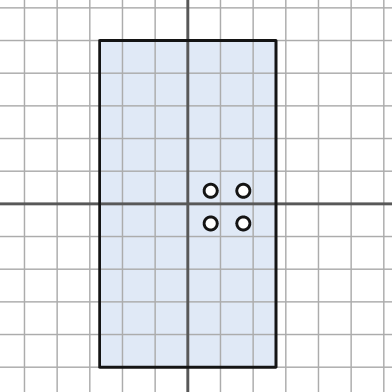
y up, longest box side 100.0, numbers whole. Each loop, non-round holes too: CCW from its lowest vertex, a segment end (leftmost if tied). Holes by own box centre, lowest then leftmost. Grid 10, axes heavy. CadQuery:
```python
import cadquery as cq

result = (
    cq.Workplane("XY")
    .moveTo(-27.0, -50.0)
    .lineTo(27.0, -50.0)
    .lineTo(27.0, 50.0)
    .lineTo(-27.0, 50.0)
    .close()
    .moveTo(7.0, -6.0)
    .circle(2.0)
    .moveTo(17.0, -6.0)
    .circle(2.0)
    .moveTo(7.0, 4.0)
    .circle(2.0)
    .moveTo(17.0, 4.0)
    .circle(2.0)
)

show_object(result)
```